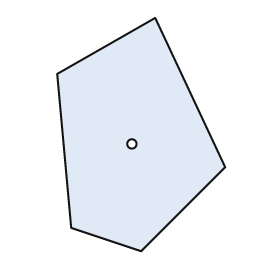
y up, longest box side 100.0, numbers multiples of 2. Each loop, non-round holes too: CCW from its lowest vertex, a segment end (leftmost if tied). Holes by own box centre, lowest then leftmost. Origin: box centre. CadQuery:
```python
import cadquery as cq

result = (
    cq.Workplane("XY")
    .moveTo(0.0, -50.0)
    .lineTo(36.0, -14.0)
    .lineTo(6.0, 50.0)
    .lineTo(-36.0, 26.0)
    .lineTo(-30.0, -40.0)
    .close()
    .moveTo(-4.0, -4.0)
    .circle(2.0)
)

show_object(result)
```